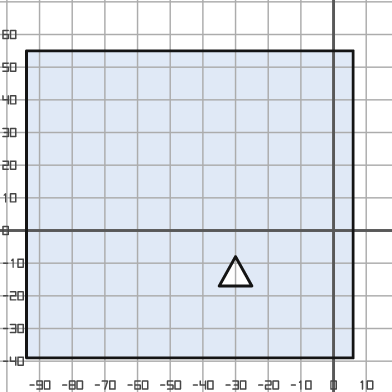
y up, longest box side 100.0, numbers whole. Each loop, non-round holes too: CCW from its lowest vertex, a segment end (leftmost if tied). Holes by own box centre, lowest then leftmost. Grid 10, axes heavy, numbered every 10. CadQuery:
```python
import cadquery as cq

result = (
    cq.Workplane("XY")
    .moveTo(-94.0, -39.0)
    .lineTo(6.0, -39.0)
    .lineTo(6.0, 55.0)
    .lineTo(-94.0, 55.0)
    .close()
    .moveTo(-35.0, -17.0)
    .lineTo(-25.0, -17.0)
    .lineTo(-30.0, -8.0)
    .close()
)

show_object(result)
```